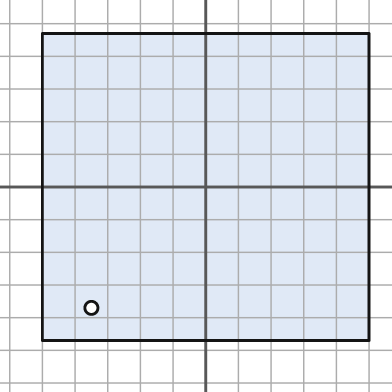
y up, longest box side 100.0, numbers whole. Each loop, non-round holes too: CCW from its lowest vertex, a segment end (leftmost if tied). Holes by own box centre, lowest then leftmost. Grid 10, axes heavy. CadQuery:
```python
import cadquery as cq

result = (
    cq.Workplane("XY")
    .moveTo(-50.0, -47.0)
    .lineTo(50.0, -47.0)
    .lineTo(50.0, 47.0)
    .lineTo(-50.0, 47.0)
    .close()
    .moveTo(-35.0, -37.0)
    .circle(2.0)
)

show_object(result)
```